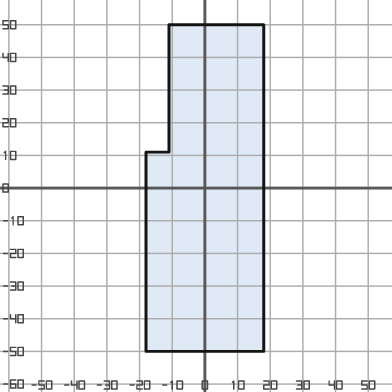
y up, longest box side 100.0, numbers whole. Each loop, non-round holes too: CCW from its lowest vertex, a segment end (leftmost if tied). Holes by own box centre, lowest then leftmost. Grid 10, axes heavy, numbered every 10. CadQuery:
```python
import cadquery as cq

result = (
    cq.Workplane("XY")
    .moveTo(-18.0, -50.0)
    .lineTo(18.0, -50.0)
    .lineTo(18.0, 50.0)
    .lineTo(-11.0, 50.0)
    .lineTo(-11.0, 11.0)
    .lineTo(-18.0, 11.0)
    .close()
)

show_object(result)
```